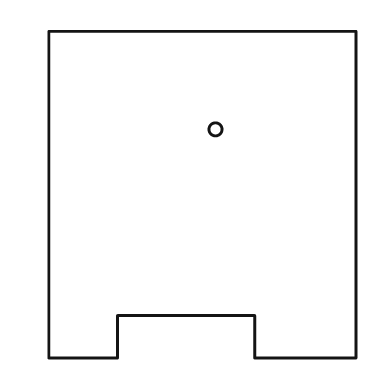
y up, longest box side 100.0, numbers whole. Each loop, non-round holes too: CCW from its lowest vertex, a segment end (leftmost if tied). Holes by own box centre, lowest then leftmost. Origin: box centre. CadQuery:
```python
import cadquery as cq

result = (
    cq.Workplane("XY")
    .moveTo(-47.0, -50.0)
    .lineTo(-26.0, -50.0)
    .lineTo(-26.0, -37.0)
    .lineTo(16.0, -37.0)
    .lineTo(16.0, -50.0)
    .lineTo(47.0, -50.0)
    .lineTo(47.0, 50.0)
    .lineTo(-47.0, 50.0)
    .close()
    .moveTo(4.0, 20.0)
    .circle(2.0)
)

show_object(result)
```